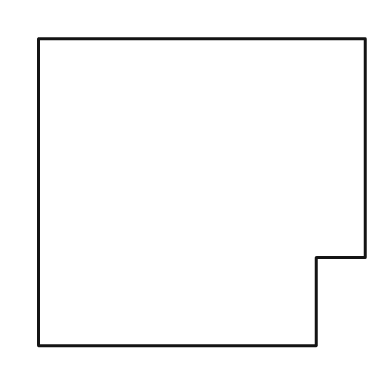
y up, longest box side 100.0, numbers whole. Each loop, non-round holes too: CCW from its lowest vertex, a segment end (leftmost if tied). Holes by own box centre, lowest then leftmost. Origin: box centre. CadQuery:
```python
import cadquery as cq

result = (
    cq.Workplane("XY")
    .moveTo(-50.0, -47.0)
    .lineTo(35.0, -47.0)
    .lineTo(35.0, -20.0)
    .lineTo(50.0, -20.0)
    .lineTo(50.0, 47.0)
    .lineTo(-50.0, 47.0)
    .close()
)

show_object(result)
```